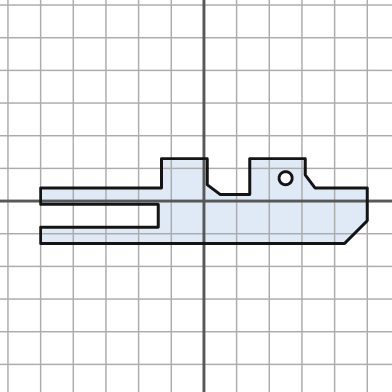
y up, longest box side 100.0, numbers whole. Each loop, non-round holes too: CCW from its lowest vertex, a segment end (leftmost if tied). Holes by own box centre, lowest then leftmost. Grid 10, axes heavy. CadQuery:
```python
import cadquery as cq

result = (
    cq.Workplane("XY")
    .moveTo(-50.0, -13.0)
    .lineTo(43.0, -13.0)
    .lineTo(50.0, -6.0)
    .lineTo(50.0, 4.0)
    .lineTo(34.0, 4.0)
    .lineTo(31.0, 8.0)
    .lineTo(31.0, 13.0)
    .lineTo(14.0, 13.0)
    .lineTo(14.0, 2.0)
    .lineTo(5.0, 2.0)
    .lineTo(1.0, 5.0)
    .lineTo(1.0, 13.0)
    .lineTo(-13.0, 13.0)
    .lineTo(-13.0, 4.0)
    .lineTo(-50.0, 4.0)
    .lineTo(-50.0, -1.0)
    .lineTo(-14.0, -1.0)
    .lineTo(-14.0, -8.0)
    .lineTo(-50.0, -8.0)
    .close()
    .moveTo(25.0, 7.0)
    .circle(2.0)
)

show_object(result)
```